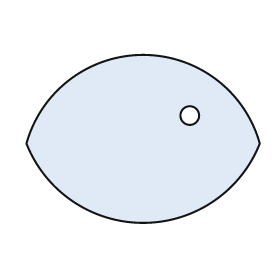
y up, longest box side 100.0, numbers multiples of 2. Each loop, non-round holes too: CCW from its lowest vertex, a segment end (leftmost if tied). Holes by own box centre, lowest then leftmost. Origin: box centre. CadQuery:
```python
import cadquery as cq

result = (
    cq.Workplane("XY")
    .moveTo(-50.0, -2.0)
    .threePointArc((0.0, -36.0), (50.0, -2.0))
    .threePointArc((0.0, 36.0), (-50.0, -2.0))
    .close()
    .moveTo(20.0, 10.0)
    .circle(4.0)
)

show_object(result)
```